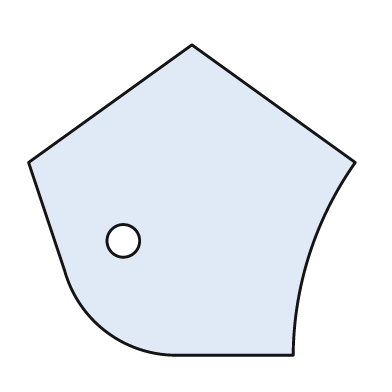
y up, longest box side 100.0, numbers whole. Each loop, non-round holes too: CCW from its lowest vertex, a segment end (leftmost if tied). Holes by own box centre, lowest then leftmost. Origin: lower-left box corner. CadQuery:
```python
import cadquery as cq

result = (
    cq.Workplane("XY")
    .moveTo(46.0, 0.0)
    .lineTo(81.0, 0.0)
    .threePointArc((86.0, 31.0), (100.0, 59.0))
    .lineTo(50.0, 95.0)
    .lineTo(0.0, 59.0)
    .lineTo(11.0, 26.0)
    .threePointArc((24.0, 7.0), (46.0, 0.0))
    .close()
    .moveTo(29.0, 35.0)
    .circle(5.0)
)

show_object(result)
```